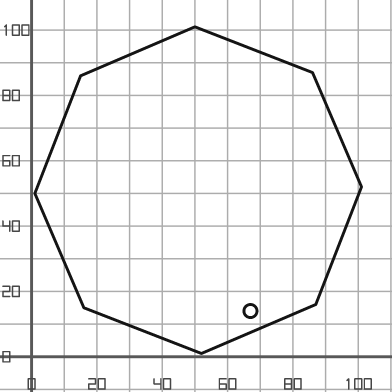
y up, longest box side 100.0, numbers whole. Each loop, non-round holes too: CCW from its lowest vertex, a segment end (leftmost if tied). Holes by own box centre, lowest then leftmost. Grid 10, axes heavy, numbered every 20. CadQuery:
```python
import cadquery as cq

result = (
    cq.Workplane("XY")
    .moveTo(52.0, 1.0)
    .lineTo(87.0, 16.0)
    .lineTo(101.0, 52.0)
    .lineTo(86.0, 87.0)
    .lineTo(50.0, 101.0)
    .lineTo(15.0, 86.0)
    .lineTo(1.0, 50.0)
    .lineTo(16.0, 15.0)
    .close()
    .moveTo(67.0, 14.0)
    .circle(2.0)
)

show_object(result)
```